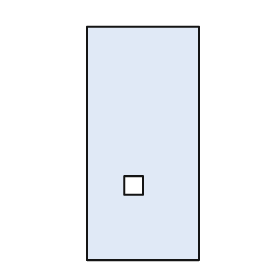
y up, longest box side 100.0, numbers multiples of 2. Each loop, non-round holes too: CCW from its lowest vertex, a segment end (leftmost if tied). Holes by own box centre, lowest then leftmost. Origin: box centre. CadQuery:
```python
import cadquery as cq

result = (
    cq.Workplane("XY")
    .moveTo(-24.0, -50.0)
    .lineTo(24.0, -50.0)
    .lineTo(24.0, 50.0)
    .lineTo(-24.0, 50.0)
    .close()
    .moveTo(-8.0, -22.0)
    .lineTo(0.0, -22.0)
    .lineTo(0.0, -14.0)
    .lineTo(-8.0, -14.0)
    .close()
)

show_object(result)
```